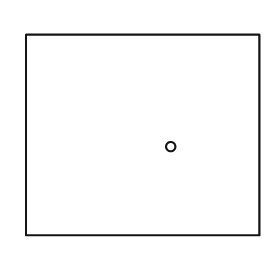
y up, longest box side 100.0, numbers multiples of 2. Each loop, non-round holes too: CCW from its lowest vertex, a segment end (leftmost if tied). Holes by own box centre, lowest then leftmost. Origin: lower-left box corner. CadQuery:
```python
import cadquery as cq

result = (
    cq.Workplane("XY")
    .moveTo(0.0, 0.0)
    .lineTo(100.0, 0.0)
    .lineTo(100.0, 86.0)
    .lineTo(0.0, 86.0)
    .close()
    .moveTo(62.0, 38.0)
    .circle(2.0)
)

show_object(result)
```